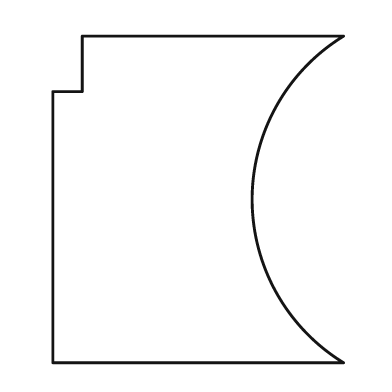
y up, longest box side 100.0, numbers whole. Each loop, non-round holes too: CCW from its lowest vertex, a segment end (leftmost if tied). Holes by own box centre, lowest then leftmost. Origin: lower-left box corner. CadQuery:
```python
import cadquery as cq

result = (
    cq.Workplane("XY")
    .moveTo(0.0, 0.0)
    .lineTo(89.0, 0.0)
    .threePointArc((61.0, 50.0), (89.0, 100.0))
    .lineTo(9.0, 100.0)
    .lineTo(9.0, 83.0)
    .lineTo(0.0, 83.0)
    .close()
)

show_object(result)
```